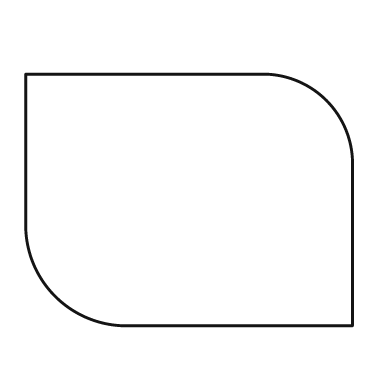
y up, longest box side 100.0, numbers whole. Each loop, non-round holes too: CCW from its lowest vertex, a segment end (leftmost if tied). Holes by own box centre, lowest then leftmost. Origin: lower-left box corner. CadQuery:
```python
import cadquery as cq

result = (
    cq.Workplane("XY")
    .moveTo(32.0, 0.0)
    .lineTo(100.0, 0.0)
    .lineTo(100.0, 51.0)
    .threePointArc((92.0, 69.0), (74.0, 77.0))
    .lineTo(0.0, 77.0)
    .lineTo(0.0, 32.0)
    .threePointArc((9.0, 9.0), (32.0, 0.0))
    .close()
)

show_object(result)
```